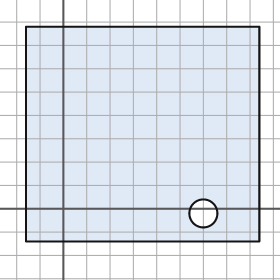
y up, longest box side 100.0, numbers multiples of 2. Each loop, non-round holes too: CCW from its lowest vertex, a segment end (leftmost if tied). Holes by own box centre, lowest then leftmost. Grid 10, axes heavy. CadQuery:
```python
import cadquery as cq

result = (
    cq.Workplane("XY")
    .moveTo(-16.0, -14.0)
    .lineTo(84.0, -14.0)
    .lineTo(84.0, 78.0)
    .lineTo(-16.0, 78.0)
    .close()
    .moveTo(60.0, -2.0)
    .circle(6.0)
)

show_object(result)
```